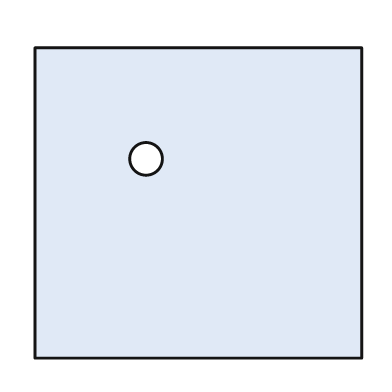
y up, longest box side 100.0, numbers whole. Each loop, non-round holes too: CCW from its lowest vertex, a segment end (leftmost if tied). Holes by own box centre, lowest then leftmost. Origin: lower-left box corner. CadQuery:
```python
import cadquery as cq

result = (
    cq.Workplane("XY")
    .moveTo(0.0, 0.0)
    .lineTo(100.0, 0.0)
    .lineTo(100.0, 95.0)
    .lineTo(0.0, 95.0)
    .close()
    .moveTo(34.0, 61.0)
    .circle(5.0)
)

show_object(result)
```